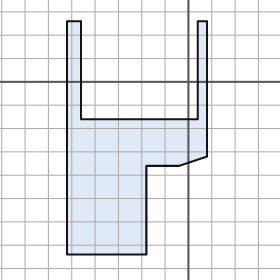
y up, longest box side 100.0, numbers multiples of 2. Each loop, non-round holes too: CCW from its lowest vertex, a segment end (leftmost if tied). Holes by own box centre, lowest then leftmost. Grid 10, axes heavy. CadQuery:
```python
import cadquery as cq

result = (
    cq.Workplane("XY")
    .moveTo(-52.0, -74.0)
    .lineTo(-18.0, -74.0)
    .lineTo(-18.0, -36.0)
    .lineTo(-4.0, -36.0)
    .lineTo(8.0, -32.0)
    .lineTo(8.0, 26.0)
    .lineTo(4.0, 26.0)
    .lineTo(4.0, -16.0)
    .lineTo(-46.0, -16.0)
    .lineTo(-46.0, 26.0)
    .lineTo(-52.0, 26.0)
    .close()
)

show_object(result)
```